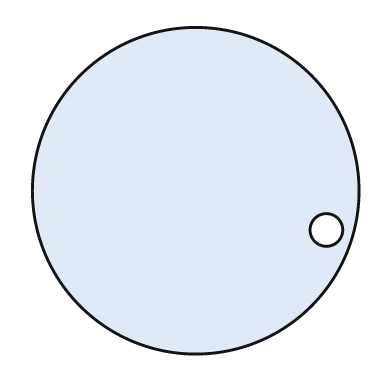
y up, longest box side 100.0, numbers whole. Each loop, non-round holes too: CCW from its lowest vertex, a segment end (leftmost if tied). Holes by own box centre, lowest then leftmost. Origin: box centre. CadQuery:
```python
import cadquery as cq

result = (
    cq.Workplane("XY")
    .moveTo(0.0, 0.0)
    .circle(50.0)
    .moveTo(40.0, -12.0)
    .circle(5.0)
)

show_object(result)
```